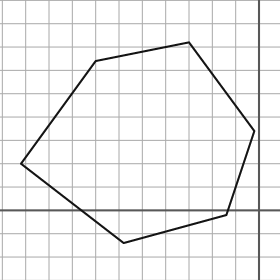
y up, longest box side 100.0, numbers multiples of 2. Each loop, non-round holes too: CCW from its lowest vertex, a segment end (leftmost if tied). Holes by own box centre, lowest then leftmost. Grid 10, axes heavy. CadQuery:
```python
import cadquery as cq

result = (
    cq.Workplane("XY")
    .moveTo(-58.0, -14.0)
    .lineTo(-14.0, -2.0)
    .lineTo(-2.0, 34.0)
    .lineTo(-30.0, 72.0)
    .lineTo(-70.0, 64.0)
    .lineTo(-102.0, 20.0)
    .close()
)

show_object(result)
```